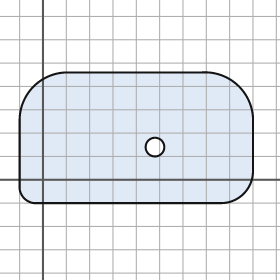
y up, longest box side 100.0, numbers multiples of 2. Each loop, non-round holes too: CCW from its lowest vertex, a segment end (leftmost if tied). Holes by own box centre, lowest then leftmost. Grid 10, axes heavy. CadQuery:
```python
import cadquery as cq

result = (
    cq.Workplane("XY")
    .moveTo(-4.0, -10.0)
    .lineTo(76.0, -10.0)
    .threePointArc((86.0, -6.0), (90.0, 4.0))
    .lineTo(90.0, 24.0)
    .threePointArc((84.0, 40.0), (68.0, 46.0))
    .lineTo(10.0, 46.0)
    .threePointArc((-4.0, 40.0), (-10.0, 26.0))
    .lineTo(-10.0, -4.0)
    .threePointArc((-8.0, -8.0), (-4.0, -10.0))
    .close()
    .moveTo(48.0, 14.0)
    .circle(4.0)
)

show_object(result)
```